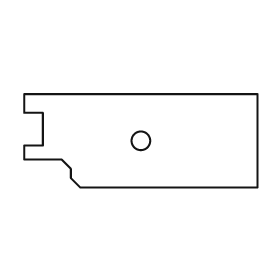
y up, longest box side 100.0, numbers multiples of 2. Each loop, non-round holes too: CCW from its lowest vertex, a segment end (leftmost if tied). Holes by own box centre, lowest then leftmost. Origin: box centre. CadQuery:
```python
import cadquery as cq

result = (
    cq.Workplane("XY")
    .moveTo(-26.0, -20.0)
    .lineTo(50.0, -20.0)
    .lineTo(50.0, 20.0)
    .lineTo(-50.0, 20.0)
    .lineTo(-50.0, 12.0)
    .lineTo(-42.0, 12.0)
    .lineTo(-42.0, -2.0)
    .lineTo(-50.0, -2.0)
    .lineTo(-50.0, -8.0)
    .lineTo(-34.0, -8.0)
    .lineTo(-30.0, -12.0)
    .lineTo(-30.0, -16.0)
    .close()
    .moveTo(0.0, 0.0)
    .circle(4.0)
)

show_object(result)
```